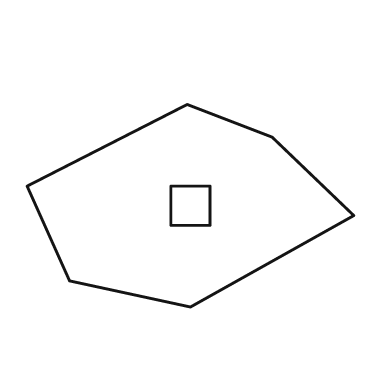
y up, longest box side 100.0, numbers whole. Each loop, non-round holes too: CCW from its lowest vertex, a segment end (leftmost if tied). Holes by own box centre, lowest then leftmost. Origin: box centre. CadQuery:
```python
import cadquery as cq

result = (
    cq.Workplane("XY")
    .moveTo(0.0, -31.0)
    .lineTo(50.0, -3.0)
    .lineTo(25.0, 21.0)
    .lineTo(-1.0, 31.0)
    .lineTo(-50.0, 6.0)
    .lineTo(-37.0, -23.0)
    .close()
    .moveTo(-6.0, -6.0)
    .lineTo(6.0, -6.0)
    .lineTo(6.0, 6.0)
    .lineTo(-6.0, 6.0)
    .close()
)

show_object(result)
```